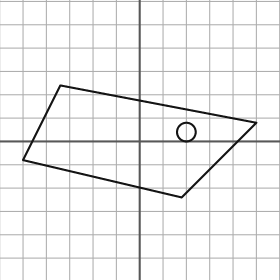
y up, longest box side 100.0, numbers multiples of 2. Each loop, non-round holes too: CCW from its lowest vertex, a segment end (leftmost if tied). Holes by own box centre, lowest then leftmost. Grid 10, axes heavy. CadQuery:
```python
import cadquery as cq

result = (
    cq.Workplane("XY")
    .moveTo(18.0, -24.0)
    .lineTo(50.0, 8.0)
    .lineTo(-34.0, 24.0)
    .lineTo(-50.0, -8.0)
    .close()
    .moveTo(20.0, 4.0)
    .circle(4.0)
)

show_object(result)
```